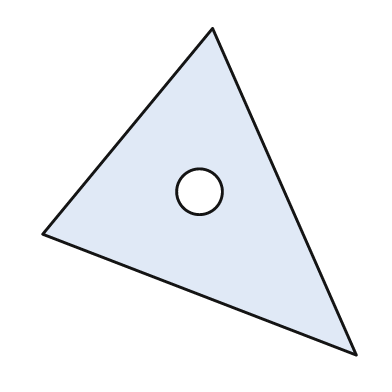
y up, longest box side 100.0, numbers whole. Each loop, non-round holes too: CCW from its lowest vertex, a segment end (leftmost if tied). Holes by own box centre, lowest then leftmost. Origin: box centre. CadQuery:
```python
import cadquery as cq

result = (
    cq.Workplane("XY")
    .moveTo(48.0, -50.0)
    .lineTo(4.0, 50.0)
    .lineTo(-48.0, -13.0)
    .close()
    .moveTo(0.0, 0.0)
    .circle(7.0)
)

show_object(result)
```